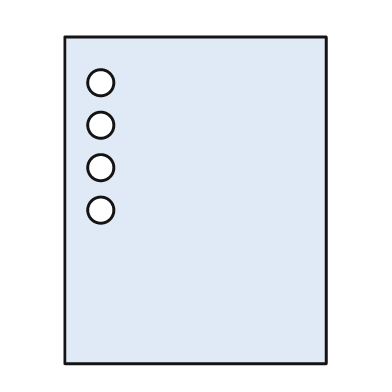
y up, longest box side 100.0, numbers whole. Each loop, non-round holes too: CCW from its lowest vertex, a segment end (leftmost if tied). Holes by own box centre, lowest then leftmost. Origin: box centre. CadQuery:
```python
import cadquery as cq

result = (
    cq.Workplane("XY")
    .moveTo(-40.0, -50.0)
    .lineTo(40.0, -50.0)
    .lineTo(40.0, 50.0)
    .lineTo(-40.0, 50.0)
    .close()
    .moveTo(-29.0, -3.0)
    .circle(4.0)
    .moveTo(-29.0, 10.0)
    .circle(4.0)
    .moveTo(-29.0, 23.0)
    .circle(4.0)
    .moveTo(-29.0, 36.0)
    .circle(4.0)
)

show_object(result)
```